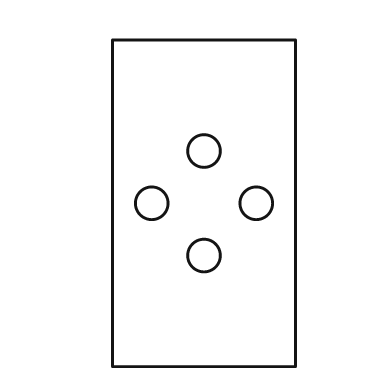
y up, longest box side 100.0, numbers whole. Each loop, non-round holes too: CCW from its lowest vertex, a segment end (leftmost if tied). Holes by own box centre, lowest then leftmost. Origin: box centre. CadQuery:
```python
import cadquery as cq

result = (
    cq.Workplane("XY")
    .moveTo(-28.0, -50.0)
    .lineTo(28.0, -50.0)
    .lineTo(28.0, 50.0)
    .lineTo(-28.0, 50.0)
    .close()
    .moveTo(0.0, -16.0)
    .circle(5.0)
    .moveTo(-16.0, 0.0)
    .circle(5.0)
    .moveTo(16.0, 0.0)
    .circle(5.0)
    .moveTo(0.0, 16.0)
    .circle(5.0)
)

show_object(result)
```